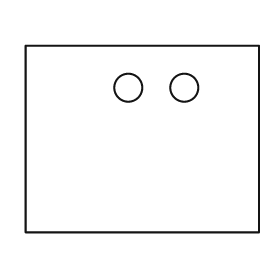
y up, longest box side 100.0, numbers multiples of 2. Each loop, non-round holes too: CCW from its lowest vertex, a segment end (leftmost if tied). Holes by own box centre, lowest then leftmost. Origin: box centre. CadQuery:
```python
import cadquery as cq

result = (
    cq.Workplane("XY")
    .moveTo(-50.0, -40.0)
    .lineTo(50.0, -40.0)
    .lineTo(50.0, 40.0)
    .lineTo(-50.0, 40.0)
    .close()
    .moveTo(-6.0, 22.0)
    .circle(6.0)
    .moveTo(18.0, 22.0)
    .circle(6.0)
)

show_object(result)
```